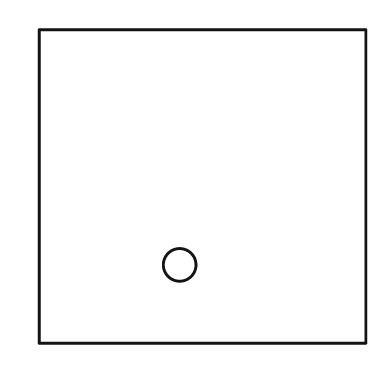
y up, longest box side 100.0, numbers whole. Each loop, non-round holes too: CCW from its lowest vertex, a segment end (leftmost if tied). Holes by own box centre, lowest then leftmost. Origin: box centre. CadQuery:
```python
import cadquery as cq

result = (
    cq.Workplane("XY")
    .moveTo(-50.0, -48.0)
    .lineTo(50.0, -48.0)
    .lineTo(50.0, 48.0)
    .lineTo(-50.0, 48.0)
    .close()
    .moveTo(-7.0, -24.0)
    .circle(5.0)
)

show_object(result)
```